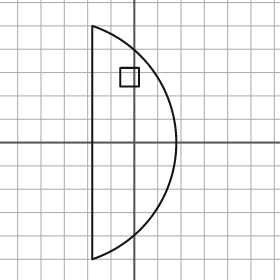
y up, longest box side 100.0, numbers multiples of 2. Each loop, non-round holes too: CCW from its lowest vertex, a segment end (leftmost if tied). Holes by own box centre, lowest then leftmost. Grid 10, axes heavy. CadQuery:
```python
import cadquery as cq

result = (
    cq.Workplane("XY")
    .moveTo(-18.0, -50.0)
    .threePointArc((18.0, 0.0), (-18.0, 50.0))
    .close()
    .moveTo(-6.0, 24.0)
    .lineTo(2.0, 24.0)
    .lineTo(2.0, 32.0)
    .lineTo(-6.0, 32.0)
    .close()
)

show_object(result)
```